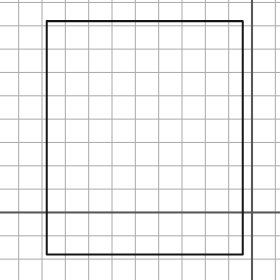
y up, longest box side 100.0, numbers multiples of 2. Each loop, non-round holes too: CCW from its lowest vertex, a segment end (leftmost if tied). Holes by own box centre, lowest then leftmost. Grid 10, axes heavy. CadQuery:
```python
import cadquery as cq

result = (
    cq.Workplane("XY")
    .moveTo(-88.0, -18.0)
    .lineTo(-4.0, -18.0)
    .lineTo(-4.0, 82.0)
    .lineTo(-88.0, 82.0)
    .close()
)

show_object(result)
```